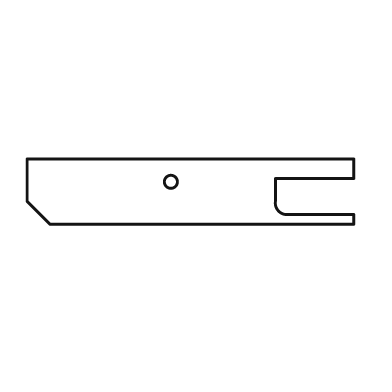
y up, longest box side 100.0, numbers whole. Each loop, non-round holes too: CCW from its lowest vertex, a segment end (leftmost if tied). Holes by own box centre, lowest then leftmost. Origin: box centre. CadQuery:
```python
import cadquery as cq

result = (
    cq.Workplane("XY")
    .moveTo(-43.0, -10.0)
    .lineTo(50.0, -10.0)
    .lineTo(50.0, -7.0)
    .lineTo(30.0, -7.0)
    .threePointArc((27.0, -6.0), (26.0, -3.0))
    .lineTo(26.0, 4.0)
    .lineTo(50.0, 4.0)
    .lineTo(50.0, 10.0)
    .lineTo(-50.0, 10.0)
    .lineTo(-50.0, -3.0)
    .close()
    .moveTo(-6.0, 3.0)
    .circle(2.0)
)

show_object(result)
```